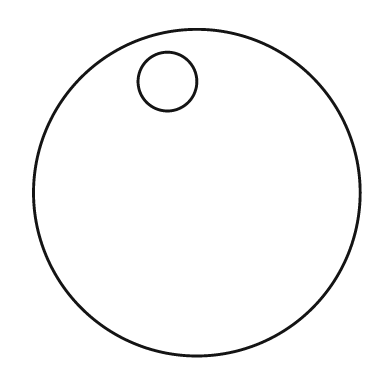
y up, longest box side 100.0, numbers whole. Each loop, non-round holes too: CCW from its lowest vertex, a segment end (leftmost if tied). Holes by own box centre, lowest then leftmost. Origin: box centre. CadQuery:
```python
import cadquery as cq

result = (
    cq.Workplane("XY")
    .moveTo(0.0, 0.0)
    .circle(50.0)
    .moveTo(-9.0, 34.0)
    .circle(9.0)
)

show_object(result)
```